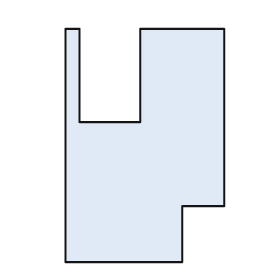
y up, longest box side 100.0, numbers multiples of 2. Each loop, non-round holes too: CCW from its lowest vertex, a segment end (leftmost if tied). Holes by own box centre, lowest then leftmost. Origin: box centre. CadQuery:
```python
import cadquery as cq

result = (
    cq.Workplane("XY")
    .moveTo(-34.0, -50.0)
    .lineTo(16.0, -50.0)
    .lineTo(16.0, -26.0)
    .lineTo(34.0, -26.0)
    .lineTo(34.0, 50.0)
    .lineTo(-2.0, 50.0)
    .lineTo(-2.0, 10.0)
    .lineTo(-28.0, 10.0)
    .lineTo(-28.0, 50.0)
    .lineTo(-34.0, 50.0)
    .close()
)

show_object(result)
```